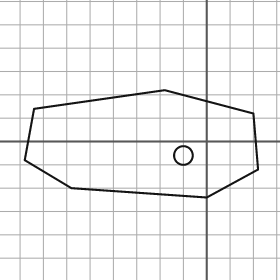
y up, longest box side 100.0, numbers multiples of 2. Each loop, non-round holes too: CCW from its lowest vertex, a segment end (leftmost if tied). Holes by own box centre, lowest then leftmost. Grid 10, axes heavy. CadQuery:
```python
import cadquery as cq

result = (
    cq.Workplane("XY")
    .moveTo(0.0, -24.0)
    .lineTo(22.0, -12.0)
    .lineTo(20.0, 12.0)
    .lineTo(-18.0, 22.0)
    .lineTo(-74.0, 14.0)
    .lineTo(-78.0, -8.0)
    .lineTo(-58.0, -20.0)
    .close()
    .moveTo(-10.0, -6.0)
    .circle(4.0)
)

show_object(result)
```